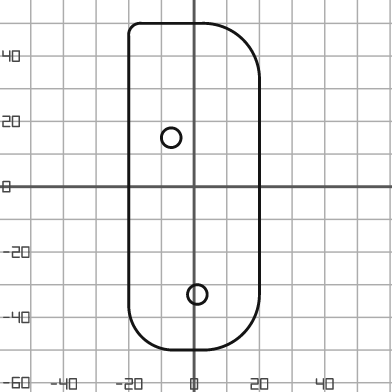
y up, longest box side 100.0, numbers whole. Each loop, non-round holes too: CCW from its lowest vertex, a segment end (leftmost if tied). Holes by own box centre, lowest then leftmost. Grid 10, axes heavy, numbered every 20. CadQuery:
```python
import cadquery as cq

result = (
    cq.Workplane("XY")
    .moveTo(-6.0, -50.0)
    .lineTo(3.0, -50.0)
    .threePointArc((15.0, -45.0), (20.0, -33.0))
    .lineTo(20.0, 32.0)
    .threePointArc((15.0, 45.0), (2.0, 50.0))
    .lineTo(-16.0, 50.0)
    .threePointArc((-19.0, 49.0), (-20.0, 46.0))
    .lineTo(-20.0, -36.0)
    .threePointArc((-16.0, -46.0), (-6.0, -50.0))
    .close()
    .moveTo(1.0, -33.0)
    .circle(3.0)
    .moveTo(-7.0, 15.0)
    .circle(3.0)
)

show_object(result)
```